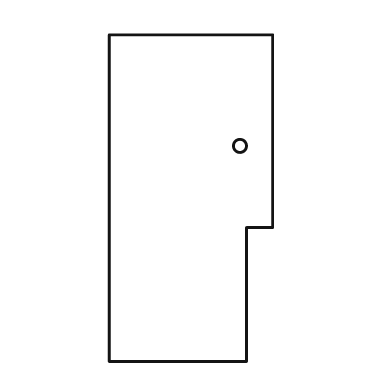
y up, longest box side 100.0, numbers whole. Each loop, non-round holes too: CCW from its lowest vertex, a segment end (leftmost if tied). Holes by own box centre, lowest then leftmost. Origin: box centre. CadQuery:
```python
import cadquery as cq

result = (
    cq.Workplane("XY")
    .moveTo(-25.0, -50.0)
    .lineTo(17.0, -50.0)
    .lineTo(17.0, -9.0)
    .lineTo(25.0, -9.0)
    .lineTo(25.0, 50.0)
    .lineTo(-25.0, 50.0)
    .close()
    .moveTo(15.0, 16.0)
    .circle(2.0)
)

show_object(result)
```